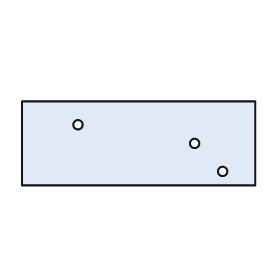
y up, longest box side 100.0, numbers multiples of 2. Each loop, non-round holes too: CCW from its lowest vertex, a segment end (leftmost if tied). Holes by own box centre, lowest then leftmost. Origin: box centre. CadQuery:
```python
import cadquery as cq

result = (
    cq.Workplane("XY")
    .moveTo(-50.0, -18.0)
    .lineTo(50.0, -18.0)
    .lineTo(50.0, 18.0)
    .lineTo(-50.0, 18.0)
    .close()
    .moveTo(36.0, -12.0)
    .circle(2.0)
    .moveTo(24.0, 0.0)
    .circle(2.0)
    .moveTo(-26.0, 8.0)
    .circle(2.0)
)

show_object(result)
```